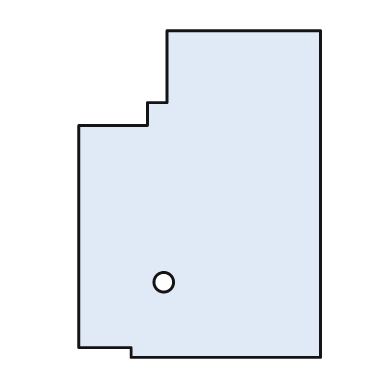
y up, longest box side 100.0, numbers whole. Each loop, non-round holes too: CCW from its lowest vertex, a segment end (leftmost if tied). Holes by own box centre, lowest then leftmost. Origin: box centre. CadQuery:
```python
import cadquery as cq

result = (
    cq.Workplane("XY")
    .moveTo(-21.0, -50.0)
    .lineTo(37.0, -50.0)
    .lineTo(37.0, 50.0)
    .lineTo(-10.0, 50.0)
    .lineTo(-10.0, 28.0)
    .lineTo(-16.0, 28.0)
    .lineTo(-16.0, 21.0)
    .lineTo(-37.0, 21.0)
    .lineTo(-37.0, -47.0)
    .lineTo(-21.0, -47.0)
    .close()
    .moveTo(-11.0, -27.0)
    .circle(3.0)
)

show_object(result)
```